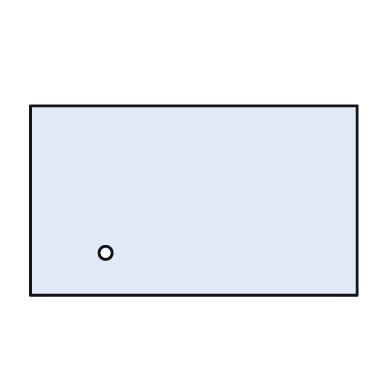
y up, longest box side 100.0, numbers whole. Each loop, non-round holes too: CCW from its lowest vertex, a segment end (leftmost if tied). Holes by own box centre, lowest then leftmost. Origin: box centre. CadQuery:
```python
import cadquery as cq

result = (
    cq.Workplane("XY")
    .moveTo(-50.0, -29.0)
    .lineTo(50.0, -29.0)
    .lineTo(50.0, 29.0)
    .lineTo(-50.0, 29.0)
    .close()
    .moveTo(-27.0, -16.0)
    .circle(2.0)
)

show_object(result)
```